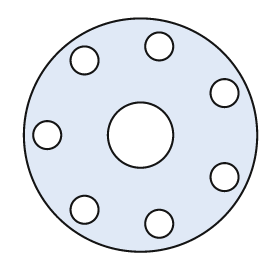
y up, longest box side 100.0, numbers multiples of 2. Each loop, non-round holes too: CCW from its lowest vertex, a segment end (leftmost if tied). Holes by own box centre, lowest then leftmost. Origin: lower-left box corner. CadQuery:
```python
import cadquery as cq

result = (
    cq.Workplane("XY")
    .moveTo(50.0, 50.0)
    .circle(50.0)
    .moveTo(58.0, 12.0)
    .circle(6.0)
    .moveTo(26.0, 18.0)
    .circle(6.0)
    .moveTo(86.0, 32.0)
    .circle(6.0)
    .moveTo(10.0, 50.0)
    .circle(6.0)
    .moveTo(50.0, 50.0)
    .circle(14.0)
    .moveTo(86.0, 68.0)
    .circle(6.0)
    .moveTo(26.0, 82.0)
    .circle(6.0)
    .moveTo(58.0, 88.0)
    .circle(6.0)
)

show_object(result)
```